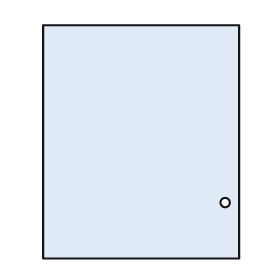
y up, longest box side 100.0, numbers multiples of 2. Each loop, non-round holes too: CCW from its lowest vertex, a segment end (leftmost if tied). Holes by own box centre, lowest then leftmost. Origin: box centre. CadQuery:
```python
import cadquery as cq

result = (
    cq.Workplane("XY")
    .moveTo(-42.0, -50.0)
    .lineTo(42.0, -50.0)
    .lineTo(42.0, 50.0)
    .lineTo(-42.0, 50.0)
    .close()
    .moveTo(36.0, -26.0)
    .circle(2.0)
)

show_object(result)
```